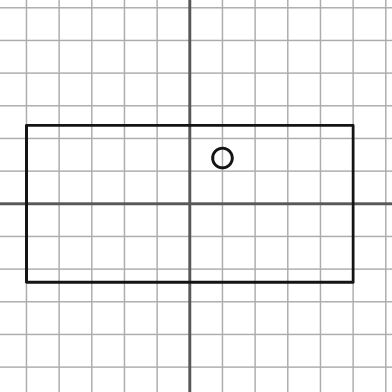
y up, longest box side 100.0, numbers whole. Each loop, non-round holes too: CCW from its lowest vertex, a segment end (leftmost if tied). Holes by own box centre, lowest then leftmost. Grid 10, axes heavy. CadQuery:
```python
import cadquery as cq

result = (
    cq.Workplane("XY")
    .moveTo(-50.0, -24.0)
    .lineTo(50.0, -24.0)
    .lineTo(50.0, 24.0)
    .lineTo(-50.0, 24.0)
    .close()
    .moveTo(10.0, 14.0)
    .circle(3.0)
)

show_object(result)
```